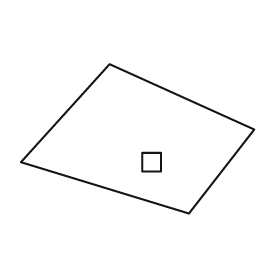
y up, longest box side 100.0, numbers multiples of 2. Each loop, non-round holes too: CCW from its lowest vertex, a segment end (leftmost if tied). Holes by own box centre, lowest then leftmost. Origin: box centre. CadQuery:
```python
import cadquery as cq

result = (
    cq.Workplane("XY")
    .moveTo(22.0, -32.0)
    .lineTo(50.0, 4.0)
    .lineTo(-12.0, 32.0)
    .lineTo(-50.0, -10.0)
    .close()
    .moveTo(2.0, -14.0)
    .lineTo(10.0, -14.0)
    .lineTo(10.0, -6.0)
    .lineTo(2.0, -6.0)
    .close()
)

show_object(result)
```